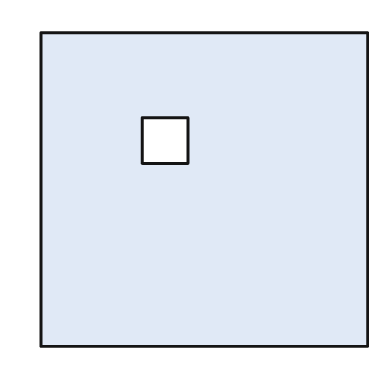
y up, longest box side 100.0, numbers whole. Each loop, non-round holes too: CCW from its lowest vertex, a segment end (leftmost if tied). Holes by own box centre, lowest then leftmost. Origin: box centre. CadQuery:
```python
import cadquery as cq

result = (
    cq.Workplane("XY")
    .moveTo(-50.0, -48.0)
    .lineTo(50.0, -48.0)
    .lineTo(50.0, 48.0)
    .lineTo(-50.0, 48.0)
    .close()
    .moveTo(-19.0, 8.0)
    .lineTo(-5.0, 8.0)
    .lineTo(-5.0, 22.0)
    .lineTo(-19.0, 22.0)
    .close()
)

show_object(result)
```